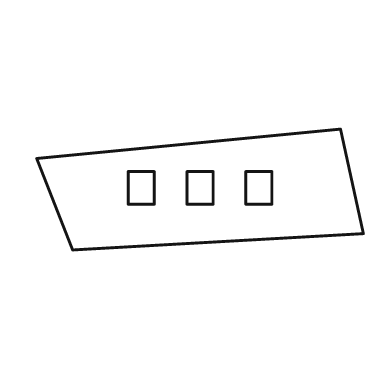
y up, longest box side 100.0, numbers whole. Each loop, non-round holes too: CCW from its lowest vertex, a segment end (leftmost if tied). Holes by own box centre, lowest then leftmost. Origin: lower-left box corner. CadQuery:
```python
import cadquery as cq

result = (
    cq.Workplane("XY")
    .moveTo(11.0, 0.0)
    .lineTo(100.0, 5.0)
    .lineTo(93.0, 37.0)
    .lineTo(0.0, 28.0)
    .close()
    .moveTo(28.0, 14.0)
    .lineTo(36.0, 14.0)
    .lineTo(36.0, 24.0)
    .lineTo(28.0, 24.0)
    .close()
    .moveTo(46.0, 14.0)
    .lineTo(54.0, 14.0)
    .lineTo(54.0, 24.0)
    .lineTo(46.0, 24.0)
    .close()
    .moveTo(64.0, 14.0)
    .lineTo(72.0, 14.0)
    .lineTo(72.0, 24.0)
    .lineTo(64.0, 24.0)
    .close()
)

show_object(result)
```